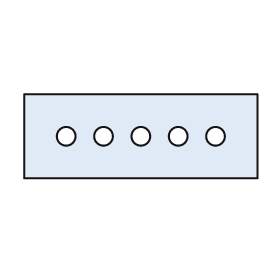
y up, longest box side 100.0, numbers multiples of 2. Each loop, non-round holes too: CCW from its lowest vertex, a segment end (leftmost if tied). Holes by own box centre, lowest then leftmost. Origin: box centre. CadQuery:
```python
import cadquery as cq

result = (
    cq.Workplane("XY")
    .moveTo(-50.0, -18.0)
    .lineTo(50.0, -18.0)
    .lineTo(50.0, 18.0)
    .lineTo(-50.0, 18.0)
    .close()
    .moveTo(-32.0, 0.0)
    .circle(4.0)
    .moveTo(-16.0, 0.0)
    .circle(4.0)
    .moveTo(0.0, 0.0)
    .circle(4.0)
    .moveTo(16.0, 0.0)
    .circle(4.0)
    .moveTo(32.0, 0.0)
    .circle(4.0)
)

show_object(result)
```